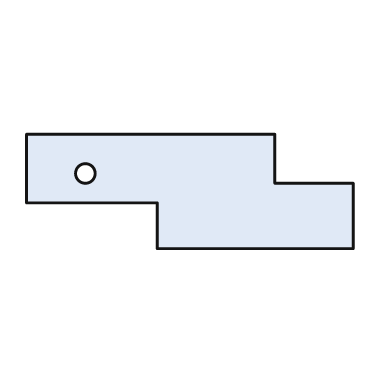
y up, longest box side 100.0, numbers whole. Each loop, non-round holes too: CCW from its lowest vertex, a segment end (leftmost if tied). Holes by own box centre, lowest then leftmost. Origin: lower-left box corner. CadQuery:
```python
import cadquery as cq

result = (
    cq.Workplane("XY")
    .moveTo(40.0, 0.0)
    .lineTo(100.0, 0.0)
    .lineTo(100.0, 20.0)
    .lineTo(76.0, 20.0)
    .lineTo(76.0, 35.0)
    .lineTo(0.0, 35.0)
    .lineTo(0.0, 14.0)
    .lineTo(40.0, 14.0)
    .close()
    .moveTo(18.0, 23.0)
    .circle(3.0)
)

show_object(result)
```